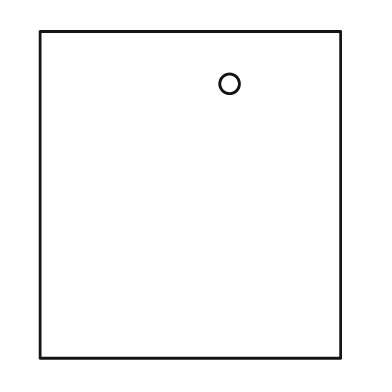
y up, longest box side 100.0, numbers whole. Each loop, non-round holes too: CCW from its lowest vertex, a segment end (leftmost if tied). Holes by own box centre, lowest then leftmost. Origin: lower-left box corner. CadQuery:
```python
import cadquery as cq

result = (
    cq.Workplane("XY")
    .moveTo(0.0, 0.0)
    .lineTo(92.0, 0.0)
    .lineTo(92.0, 100.0)
    .lineTo(0.0, 100.0)
    .close()
    .moveTo(58.0, 84.0)
    .circle(3.0)
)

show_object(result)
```